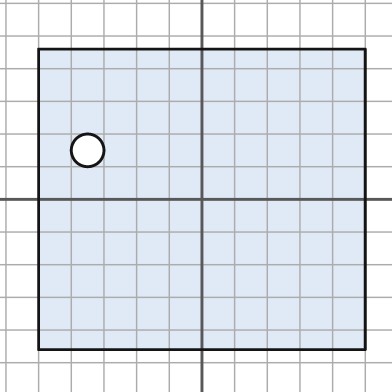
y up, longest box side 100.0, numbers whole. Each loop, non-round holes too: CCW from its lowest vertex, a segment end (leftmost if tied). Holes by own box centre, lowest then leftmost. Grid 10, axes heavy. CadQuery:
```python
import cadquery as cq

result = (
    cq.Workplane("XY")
    .moveTo(-50.0, -46.0)
    .lineTo(50.0, -46.0)
    .lineTo(50.0, 46.0)
    .lineTo(-50.0, 46.0)
    .close()
    .moveTo(-35.0, 15.0)
    .circle(5.0)
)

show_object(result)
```